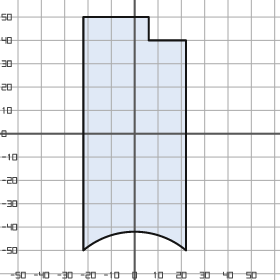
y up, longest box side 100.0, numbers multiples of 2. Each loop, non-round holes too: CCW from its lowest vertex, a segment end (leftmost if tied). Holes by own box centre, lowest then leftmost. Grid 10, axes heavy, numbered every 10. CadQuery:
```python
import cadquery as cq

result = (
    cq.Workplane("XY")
    .moveTo(-22.0, -50.0)
    .threePointArc((0.0, -42.0), (22.0, -50.0))
    .lineTo(22.0, 40.0)
    .lineTo(6.0, 40.0)
    .lineTo(6.0, 50.0)
    .lineTo(-22.0, 50.0)
    .close()
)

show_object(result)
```